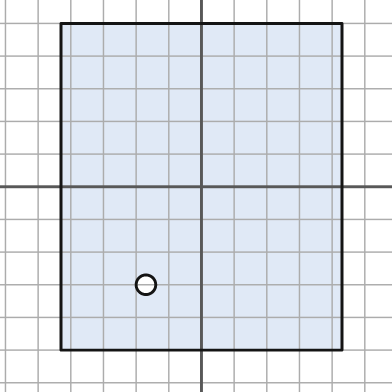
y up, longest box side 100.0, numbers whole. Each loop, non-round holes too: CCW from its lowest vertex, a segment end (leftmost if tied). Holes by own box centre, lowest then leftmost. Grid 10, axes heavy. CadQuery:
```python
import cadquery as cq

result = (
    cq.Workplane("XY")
    .moveTo(-43.0, -50.0)
    .lineTo(43.0, -50.0)
    .lineTo(43.0, 50.0)
    .lineTo(-43.0, 50.0)
    .close()
    .moveTo(-17.0, -30.0)
    .circle(3.0)
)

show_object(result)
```